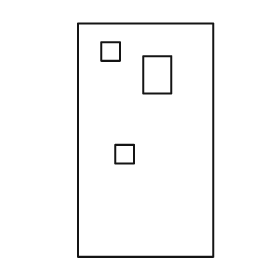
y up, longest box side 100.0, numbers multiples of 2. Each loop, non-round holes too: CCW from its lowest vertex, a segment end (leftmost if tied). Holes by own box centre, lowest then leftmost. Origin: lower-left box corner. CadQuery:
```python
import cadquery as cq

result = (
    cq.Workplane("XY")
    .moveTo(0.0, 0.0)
    .lineTo(58.0, 0.0)
    .lineTo(58.0, 100.0)
    .lineTo(0.0, 100.0)
    .close()
    .moveTo(16.0, 40.0)
    .lineTo(24.0, 40.0)
    .lineTo(24.0, 48.0)
    .lineTo(16.0, 48.0)
    .close()
    .moveTo(28.0, 70.0)
    .lineTo(40.0, 70.0)
    .lineTo(40.0, 86.0)
    .lineTo(28.0, 86.0)
    .close()
    .moveTo(10.0, 84.0)
    .lineTo(18.0, 84.0)
    .lineTo(18.0, 92.0)
    .lineTo(10.0, 92.0)
    .close()
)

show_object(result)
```